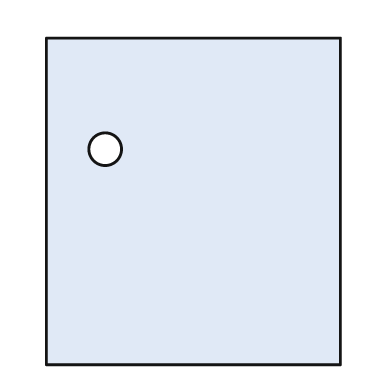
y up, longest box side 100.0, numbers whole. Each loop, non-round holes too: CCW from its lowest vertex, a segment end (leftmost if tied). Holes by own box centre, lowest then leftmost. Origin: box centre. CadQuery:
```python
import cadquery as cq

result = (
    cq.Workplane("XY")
    .moveTo(-45.0, -50.0)
    .lineTo(45.0, -50.0)
    .lineTo(45.0, 50.0)
    .lineTo(-45.0, 50.0)
    .close()
    .moveTo(-27.0, 16.0)
    .circle(5.0)
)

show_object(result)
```